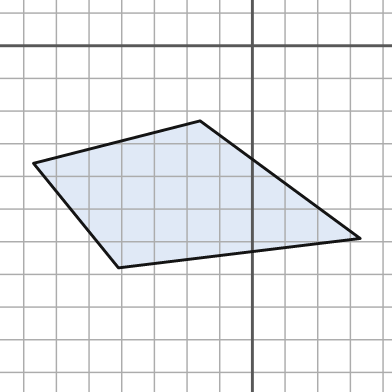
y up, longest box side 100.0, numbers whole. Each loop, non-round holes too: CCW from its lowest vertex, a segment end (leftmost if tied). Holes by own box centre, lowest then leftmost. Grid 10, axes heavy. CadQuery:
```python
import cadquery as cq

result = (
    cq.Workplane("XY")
    .moveTo(-41.0, -68.0)
    .lineTo(33.0, -59.0)
    .lineTo(-16.0, -23.0)
    .lineTo(-67.0, -36.0)
    .close()
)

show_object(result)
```